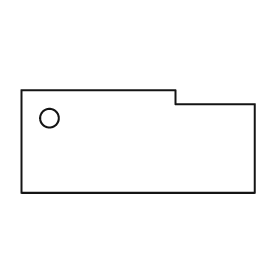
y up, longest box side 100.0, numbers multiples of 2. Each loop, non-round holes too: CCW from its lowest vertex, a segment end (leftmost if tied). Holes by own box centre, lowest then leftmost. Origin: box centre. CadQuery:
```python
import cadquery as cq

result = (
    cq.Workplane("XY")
    .moveTo(-50.0, -22.0)
    .lineTo(50.0, -22.0)
    .lineTo(50.0, 16.0)
    .lineTo(16.0, 16.0)
    .lineTo(16.0, 22.0)
    .lineTo(-50.0, 22.0)
    .close()
    .moveTo(-38.0, 10.0)
    .circle(4.0)
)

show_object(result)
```